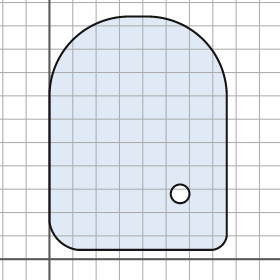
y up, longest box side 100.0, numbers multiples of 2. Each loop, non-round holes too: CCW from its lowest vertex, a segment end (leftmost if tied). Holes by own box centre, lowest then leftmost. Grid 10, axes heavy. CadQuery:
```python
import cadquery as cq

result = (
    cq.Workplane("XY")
    .moveTo(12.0, 4.0)
    .lineTo(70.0, 4.0)
    .threePointArc((74.0, 6.0), (76.0, 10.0))
    .lineTo(76.0, 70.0)
    .threePointArc((66.0, 94.0), (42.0, 104.0))
    .lineTo(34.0, 104.0)
    .threePointArc((10.0, 94.0), (0.0, 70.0))
    .lineTo(0.0, 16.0)
    .threePointArc((4.0, 8.0), (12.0, 4.0))
    .close()
    .moveTo(56.0, 28.0)
    .circle(4.0)
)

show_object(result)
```